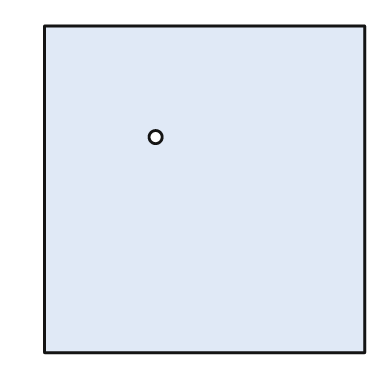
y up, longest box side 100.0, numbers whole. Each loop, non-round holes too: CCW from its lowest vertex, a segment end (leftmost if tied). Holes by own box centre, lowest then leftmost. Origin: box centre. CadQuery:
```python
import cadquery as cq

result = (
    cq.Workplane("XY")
    .moveTo(-49.0, -50.0)
    .lineTo(49.0, -50.0)
    .lineTo(49.0, 50.0)
    .lineTo(-49.0, 50.0)
    .close()
    .moveTo(-15.0, 16.0)
    .circle(2.0)
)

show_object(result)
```